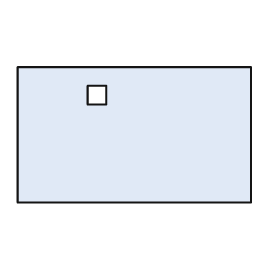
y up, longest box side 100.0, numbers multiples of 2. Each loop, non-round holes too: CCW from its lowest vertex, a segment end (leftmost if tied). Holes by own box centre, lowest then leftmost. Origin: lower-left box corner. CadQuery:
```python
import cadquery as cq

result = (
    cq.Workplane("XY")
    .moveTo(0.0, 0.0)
    .lineTo(100.0, 0.0)
    .lineTo(100.0, 58.0)
    .lineTo(0.0, 58.0)
    .close()
    .moveTo(30.0, 42.0)
    .lineTo(38.0, 42.0)
    .lineTo(38.0, 50.0)
    .lineTo(30.0, 50.0)
    .close()
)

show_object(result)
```